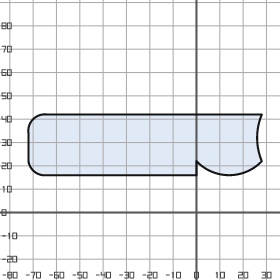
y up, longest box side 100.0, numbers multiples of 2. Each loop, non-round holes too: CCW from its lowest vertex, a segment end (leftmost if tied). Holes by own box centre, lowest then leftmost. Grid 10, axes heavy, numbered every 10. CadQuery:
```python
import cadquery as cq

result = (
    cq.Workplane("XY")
    .moveTo(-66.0, 16.0)
    .lineTo(0.0, 16.0)
    .lineTo(0.0, 22.0)
    .threePointArc((14.0, 16.0), (28.0, 22.0))
    .threePointArc((26.0, 32.0), (28.0, 42.0))
    .lineTo(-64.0, 42.0)
    .threePointArc((-70.0, 40.0), (-72.0, 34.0))
    .lineTo(-72.0, 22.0)
    .threePointArc((-70.0, 18.0), (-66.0, 16.0))
    .close()
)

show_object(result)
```